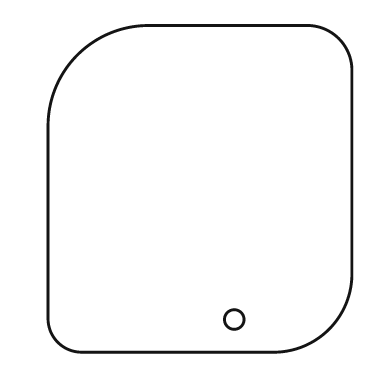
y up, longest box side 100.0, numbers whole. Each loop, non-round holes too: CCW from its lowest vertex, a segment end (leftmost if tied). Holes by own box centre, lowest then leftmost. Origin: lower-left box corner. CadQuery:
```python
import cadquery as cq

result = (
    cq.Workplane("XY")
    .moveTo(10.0, 0.0)
    .lineTo(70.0, 0.0)
    .threePointArc((86.0, 7.0), (93.0, 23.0))
    .lineTo(93.0, 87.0)
    .threePointArc((89.0, 96.0), (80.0, 100.0))
    .lineTo(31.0, 100.0)
    .threePointArc((9.0, 91.0), (0.0, 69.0))
    .lineTo(0.0, 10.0)
    .threePointArc((3.0, 3.0), (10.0, 0.0))
    .close()
    .moveTo(57.0, 10.0)
    .circle(3.0)
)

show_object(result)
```